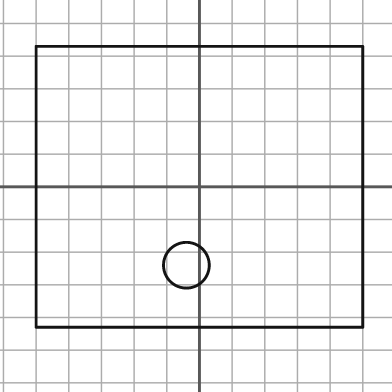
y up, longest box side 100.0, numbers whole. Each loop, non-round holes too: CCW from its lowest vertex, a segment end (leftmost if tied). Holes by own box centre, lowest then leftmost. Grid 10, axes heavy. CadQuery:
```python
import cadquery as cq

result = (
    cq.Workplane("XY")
    .moveTo(-50.0, -43.0)
    .lineTo(50.0, -43.0)
    .lineTo(50.0, 43.0)
    .lineTo(-50.0, 43.0)
    .close()
    .moveTo(-4.0, -24.0)
    .circle(7.0)
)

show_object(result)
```